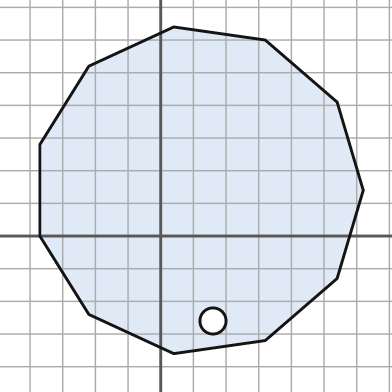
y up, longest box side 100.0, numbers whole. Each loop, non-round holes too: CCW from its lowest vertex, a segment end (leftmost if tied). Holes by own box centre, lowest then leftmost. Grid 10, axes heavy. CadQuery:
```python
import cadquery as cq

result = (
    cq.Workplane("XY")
    .moveTo(4.0, -36.0)
    .lineTo(32.0, -32.0)
    .lineTo(54.0, -13.0)
    .lineTo(62.0, 14.0)
    .lineTo(54.0, 41.0)
    .lineTo(32.0, 60.0)
    .lineTo(4.0, 64.0)
    .lineTo(-22.0, 52.0)
    .lineTo(-37.0, 28.0)
    .lineTo(-37.0, 0.0)
    .lineTo(-22.0, -24.0)
    .close()
    .moveTo(16.0, -26.0)
    .circle(4.0)
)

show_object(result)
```